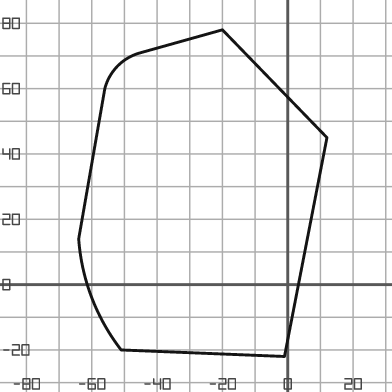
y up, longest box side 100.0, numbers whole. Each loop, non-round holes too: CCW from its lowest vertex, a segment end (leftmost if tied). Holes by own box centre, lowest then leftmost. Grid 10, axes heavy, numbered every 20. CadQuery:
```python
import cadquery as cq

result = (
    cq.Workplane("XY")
    .moveTo(-1.0, -22.0)
    .lineTo(12.0, 45.0)
    .lineTo(-20.0, 78.0)
    .lineTo(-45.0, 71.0)
    .threePointArc((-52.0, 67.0), (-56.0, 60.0))
    .lineTo(-64.0, 14.0)
    .threePointArc((-60.0, -4.0), (-51.0, -20.0))
    .close()
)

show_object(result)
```